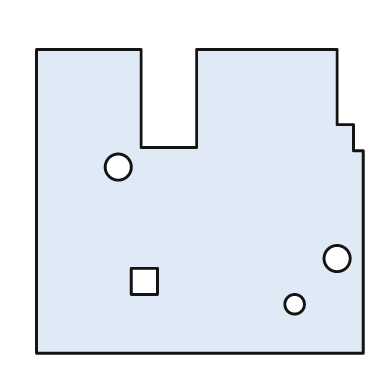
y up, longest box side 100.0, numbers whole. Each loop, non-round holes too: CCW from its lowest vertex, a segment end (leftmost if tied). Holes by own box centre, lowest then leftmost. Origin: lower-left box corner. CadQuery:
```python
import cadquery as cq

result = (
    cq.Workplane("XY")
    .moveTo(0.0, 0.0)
    .lineTo(100.0, 0.0)
    .lineTo(100.0, 62.0)
    .lineTo(97.0, 62.0)
    .lineTo(97.0, 70.0)
    .lineTo(92.0, 70.0)
    .lineTo(92.0, 93.0)
    .lineTo(49.0, 93.0)
    .lineTo(49.0, 63.0)
    .lineTo(32.0, 63.0)
    .lineTo(32.0, 93.0)
    .lineTo(0.0, 93.0)
    .close()
    .moveTo(79.0, 15.0)
    .circle(3.0)
    .moveTo(29.0, 18.0)
    .lineTo(37.0, 18.0)
    .lineTo(37.0, 26.0)
    .lineTo(29.0, 26.0)
    .close()
    .moveTo(92.0, 29.0)
    .circle(4.0)
    .moveTo(25.0, 57.0)
    .circle(4.0)
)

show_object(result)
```